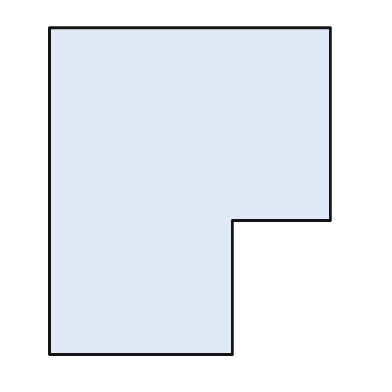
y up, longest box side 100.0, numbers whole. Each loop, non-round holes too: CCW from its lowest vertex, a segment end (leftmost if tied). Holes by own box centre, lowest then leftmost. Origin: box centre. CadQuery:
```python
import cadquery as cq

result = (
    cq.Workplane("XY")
    .moveTo(-43.0, -50.0)
    .lineTo(13.0, -50.0)
    .lineTo(13.0, -9.0)
    .lineTo(43.0, -9.0)
    .lineTo(43.0, 50.0)
    .lineTo(-43.0, 50.0)
    .close()
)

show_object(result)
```